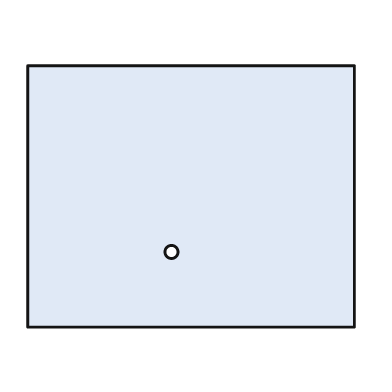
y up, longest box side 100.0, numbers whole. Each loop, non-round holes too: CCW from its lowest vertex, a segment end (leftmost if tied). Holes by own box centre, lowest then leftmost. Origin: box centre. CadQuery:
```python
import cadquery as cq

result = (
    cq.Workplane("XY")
    .moveTo(-50.0, -40.0)
    .lineTo(50.0, -40.0)
    .lineTo(50.0, 40.0)
    .lineTo(-50.0, 40.0)
    .close()
    .moveTo(-6.0, -17.0)
    .circle(2.0)
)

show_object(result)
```